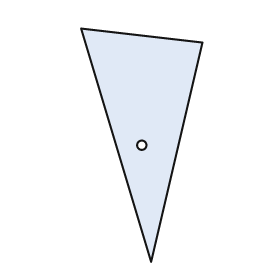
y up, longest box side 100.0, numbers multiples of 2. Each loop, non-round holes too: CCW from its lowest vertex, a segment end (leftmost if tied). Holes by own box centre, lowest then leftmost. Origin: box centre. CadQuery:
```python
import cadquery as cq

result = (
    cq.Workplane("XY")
    .moveTo(4.0, -50.0)
    .lineTo(26.0, 44.0)
    .lineTo(-26.0, 50.0)
    .close()
    .moveTo(0.0, 0.0)
    .circle(2.0)
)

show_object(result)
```